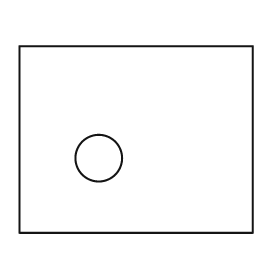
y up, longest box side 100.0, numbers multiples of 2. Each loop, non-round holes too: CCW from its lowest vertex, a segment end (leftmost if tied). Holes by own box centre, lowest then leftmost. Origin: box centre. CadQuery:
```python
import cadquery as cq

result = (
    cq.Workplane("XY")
    .moveTo(-50.0, -40.0)
    .lineTo(50.0, -40.0)
    .lineTo(50.0, 40.0)
    .lineTo(-50.0, 40.0)
    .close()
    .moveTo(-16.0, -8.0)
    .circle(10.0)
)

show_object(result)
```